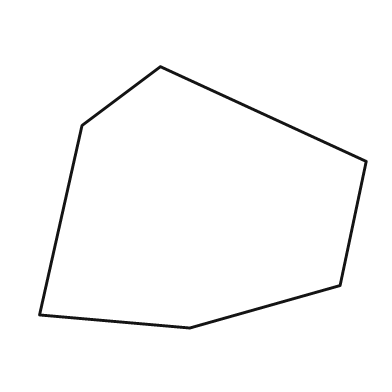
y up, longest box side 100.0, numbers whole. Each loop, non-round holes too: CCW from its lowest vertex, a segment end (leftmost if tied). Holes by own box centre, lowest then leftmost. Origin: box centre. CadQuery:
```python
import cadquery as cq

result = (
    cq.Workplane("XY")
    .moveTo(-4.0, -40.0)
    .lineTo(42.0, -27.0)
    .lineTo(50.0, 11.0)
    .lineTo(-13.0, 40.0)
    .lineTo(-37.0, 22.0)
    .lineTo(-50.0, -36.0)
    .close()
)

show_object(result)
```